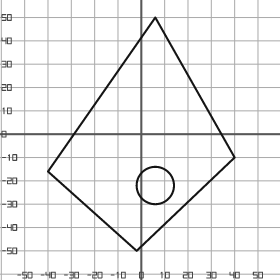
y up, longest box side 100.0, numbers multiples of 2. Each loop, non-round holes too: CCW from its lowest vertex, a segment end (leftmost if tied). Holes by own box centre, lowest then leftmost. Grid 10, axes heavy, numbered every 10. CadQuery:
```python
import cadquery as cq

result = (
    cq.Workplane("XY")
    .moveTo(-2.0, -50.0)
    .lineTo(40.0, -10.0)
    .lineTo(6.0, 50.0)
    .lineTo(-40.0, -16.0)
    .close()
    .moveTo(6.0, -22.0)
    .circle(8.0)
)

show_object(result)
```